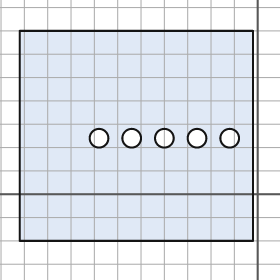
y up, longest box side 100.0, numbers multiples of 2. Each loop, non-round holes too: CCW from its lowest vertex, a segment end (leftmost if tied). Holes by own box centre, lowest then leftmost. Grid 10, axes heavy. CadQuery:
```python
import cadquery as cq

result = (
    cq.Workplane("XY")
    .moveTo(-102.0, -20.0)
    .lineTo(-2.0, -20.0)
    .lineTo(-2.0, 70.0)
    .lineTo(-102.0, 70.0)
    .close()
    .moveTo(-68.0, 24.0)
    .circle(4.0)
    .moveTo(-54.0, 24.0)
    .circle(4.0)
    .moveTo(-40.0, 24.0)
    .circle(4.0)
    .moveTo(-26.0, 24.0)
    .circle(4.0)
    .moveTo(-12.0, 24.0)
    .circle(4.0)
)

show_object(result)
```